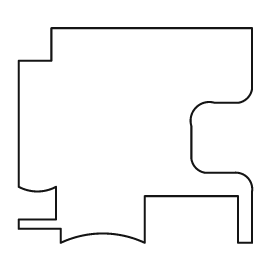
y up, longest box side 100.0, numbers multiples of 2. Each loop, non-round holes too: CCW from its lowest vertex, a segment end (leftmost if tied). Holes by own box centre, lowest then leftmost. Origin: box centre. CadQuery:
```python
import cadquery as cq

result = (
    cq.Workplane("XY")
    .moveTo(-32.0, -46.0)
    .threePointArc((-14.0, -42.0), (4.0, -46.0))
    .lineTo(4.0, -26.0)
    .lineTo(44.0, -26.0)
    .lineTo(44.0, -46.0)
    .lineTo(50.0, -46.0)
    .lineTo(50.0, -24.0)
    .threePointArc((48.0, -18.0), (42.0, -16.0))
    .lineTo(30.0, -16.0)
    .threePointArc((26.0, -14.0), (24.0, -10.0))
    .lineTo(24.0, 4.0)
    .threePointArc((26.0, 12.0), (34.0, 14.0))
    .lineTo(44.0, 14.0)
    .threePointArc((48.0, 16.0), (50.0, 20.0))
    .lineTo(50.0, 46.0)
    .lineTo(-36.0, 46.0)
    .lineTo(-36.0, 32.0)
    .lineTo(-50.0, 32.0)
    .lineTo(-50.0, -22.0)
    .threePointArc((-42.0, -24.0), (-34.0, -22.0))
    .lineTo(-34.0, -36.0)
    .lineTo(-50.0, -36.0)
    .lineTo(-50.0, -40.0)
    .lineTo(-32.0, -40.0)
    .close()
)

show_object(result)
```